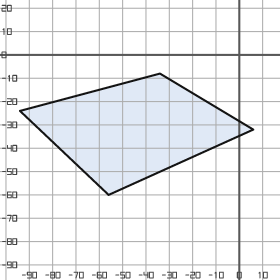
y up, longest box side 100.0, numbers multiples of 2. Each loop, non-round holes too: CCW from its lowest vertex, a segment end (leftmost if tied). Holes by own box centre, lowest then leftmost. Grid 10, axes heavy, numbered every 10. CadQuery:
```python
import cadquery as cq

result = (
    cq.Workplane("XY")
    .moveTo(-56.0, -60.0)
    .lineTo(6.0, -32.0)
    .lineTo(-34.0, -8.0)
    .lineTo(-94.0, -24.0)
    .close()
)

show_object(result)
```